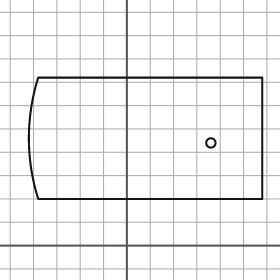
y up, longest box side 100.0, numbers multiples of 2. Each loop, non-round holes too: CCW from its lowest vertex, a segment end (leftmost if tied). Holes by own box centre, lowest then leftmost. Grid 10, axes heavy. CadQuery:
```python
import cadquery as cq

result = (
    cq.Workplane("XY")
    .moveTo(-38.0, 20.0)
    .lineTo(58.0, 20.0)
    .lineTo(58.0, 72.0)
    .lineTo(-38.0, 72.0)
    .threePointArc((-42.0, 46.0), (-38.0, 20.0))
    .close()
    .moveTo(36.0, 44.0)
    .circle(2.0)
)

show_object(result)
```